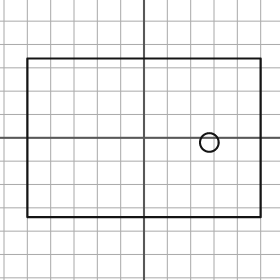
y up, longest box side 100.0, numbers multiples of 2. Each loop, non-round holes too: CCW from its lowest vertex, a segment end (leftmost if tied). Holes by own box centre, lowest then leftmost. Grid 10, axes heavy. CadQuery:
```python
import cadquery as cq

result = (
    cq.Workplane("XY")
    .moveTo(-50.0, -34.0)
    .lineTo(50.0, -34.0)
    .lineTo(50.0, 34.0)
    .lineTo(-50.0, 34.0)
    .close()
    .moveTo(28.0, -2.0)
    .circle(4.0)
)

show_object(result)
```